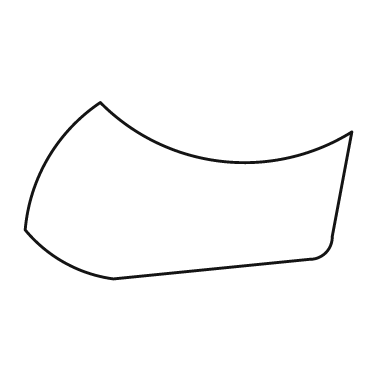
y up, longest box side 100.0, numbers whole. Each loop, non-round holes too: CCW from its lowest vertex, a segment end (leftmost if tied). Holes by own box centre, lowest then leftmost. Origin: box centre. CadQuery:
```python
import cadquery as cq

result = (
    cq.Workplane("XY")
    .moveTo(-23.0, -27.0)
    .lineTo(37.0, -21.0)
    .threePointArc((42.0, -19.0), (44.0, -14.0))
    .lineTo(50.0, 18.0)
    .threePointArc((10.0, 9.0), (-27.0, 27.0))
    .threePointArc((-43.0, 10.0), (-50.0, -12.0))
    .threePointArc((-38.0, -22.0), (-23.0, -27.0))
    .close()
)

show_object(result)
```